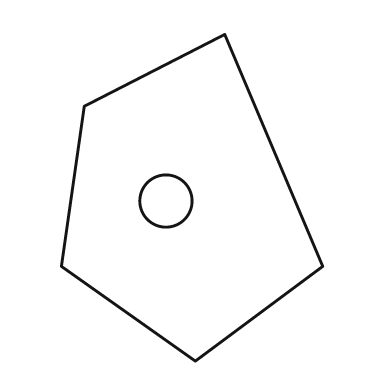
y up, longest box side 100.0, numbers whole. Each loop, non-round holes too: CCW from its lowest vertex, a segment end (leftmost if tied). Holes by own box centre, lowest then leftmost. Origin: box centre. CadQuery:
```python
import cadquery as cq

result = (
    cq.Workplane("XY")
    .moveTo(1.0, -50.0)
    .lineTo(40.0, -21.0)
    .lineTo(10.0, 50.0)
    .lineTo(-33.0, 28.0)
    .lineTo(-40.0, -21.0)
    .close()
    .moveTo(-8.0, -1.0)
    .circle(8.0)
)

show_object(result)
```